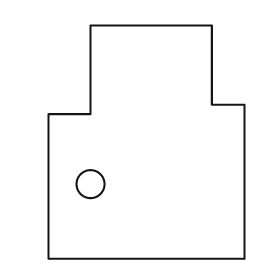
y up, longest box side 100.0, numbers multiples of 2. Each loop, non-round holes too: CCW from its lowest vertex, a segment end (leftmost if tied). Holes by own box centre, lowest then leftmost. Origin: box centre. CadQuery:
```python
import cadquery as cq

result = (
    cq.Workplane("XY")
    .moveTo(-42.0, -50.0)
    .lineTo(42.0, -50.0)
    .lineTo(42.0, 16.0)
    .lineTo(28.0, 16.0)
    .lineTo(28.0, 50.0)
    .lineTo(-24.0, 50.0)
    .lineTo(-24.0, 12.0)
    .lineTo(-42.0, 12.0)
    .close()
    .moveTo(-24.0, -18.0)
    .circle(6.0)
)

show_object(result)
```